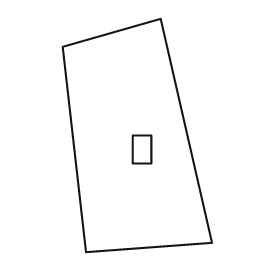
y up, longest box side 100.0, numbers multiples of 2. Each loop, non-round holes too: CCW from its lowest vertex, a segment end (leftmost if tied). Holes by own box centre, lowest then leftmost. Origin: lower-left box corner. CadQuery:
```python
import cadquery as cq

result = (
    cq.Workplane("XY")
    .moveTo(10.0, 0.0)
    .lineTo(64.0, 4.0)
    .lineTo(42.0, 100.0)
    .lineTo(0.0, 88.0)
    .close()
    .moveTo(30.0, 38.0)
    .lineTo(38.0, 38.0)
    .lineTo(38.0, 50.0)
    .lineTo(30.0, 50.0)
    .close()
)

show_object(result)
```